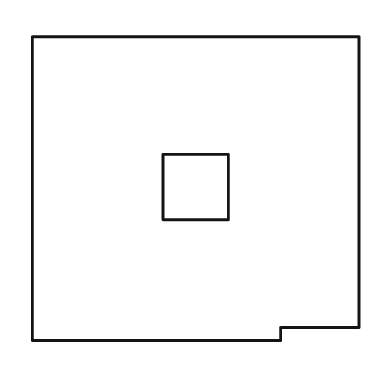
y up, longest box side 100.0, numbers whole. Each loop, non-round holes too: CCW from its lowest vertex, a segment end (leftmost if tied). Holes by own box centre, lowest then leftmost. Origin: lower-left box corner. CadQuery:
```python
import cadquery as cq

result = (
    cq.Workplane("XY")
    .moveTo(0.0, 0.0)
    .lineTo(76.0, 0.0)
    .lineTo(76.0, 4.0)
    .lineTo(100.0, 4.0)
    .lineTo(100.0, 93.0)
    .lineTo(0.0, 93.0)
    .close()
    .moveTo(40.0, 37.0)
    .lineTo(60.0, 37.0)
    .lineTo(60.0, 57.0)
    .lineTo(40.0, 57.0)
    .close()
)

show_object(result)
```